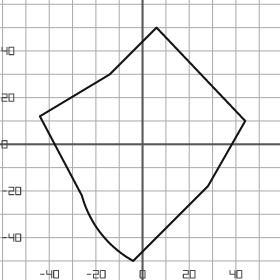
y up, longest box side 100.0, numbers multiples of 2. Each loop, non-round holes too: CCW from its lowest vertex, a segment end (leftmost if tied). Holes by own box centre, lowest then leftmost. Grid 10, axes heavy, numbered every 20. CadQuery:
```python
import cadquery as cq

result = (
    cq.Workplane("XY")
    .moveTo(-4.0, -50.0)
    .lineTo(28.0, -18.0)
    .lineTo(44.0, 10.0)
    .lineTo(6.0, 50.0)
    .lineTo(-14.0, 30.0)
    .lineTo(-44.0, 12.0)
    .lineTo(-26.0, -22.0)
    .threePointArc((-18.0, -38.0), (-4.0, -50.0))
    .close()
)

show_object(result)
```